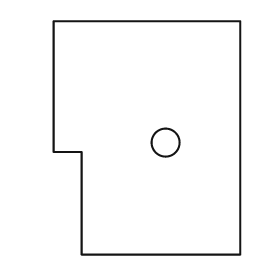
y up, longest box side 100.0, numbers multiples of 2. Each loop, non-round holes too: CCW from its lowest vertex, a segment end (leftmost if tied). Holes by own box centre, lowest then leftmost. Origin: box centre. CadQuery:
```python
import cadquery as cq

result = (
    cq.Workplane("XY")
    .moveTo(-28.0, -50.0)
    .lineTo(40.0, -50.0)
    .lineTo(40.0, 50.0)
    .lineTo(-40.0, 50.0)
    .lineTo(-40.0, -6.0)
    .lineTo(-28.0, -6.0)
    .close()
    .moveTo(8.0, -2.0)
    .circle(6.0)
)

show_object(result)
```